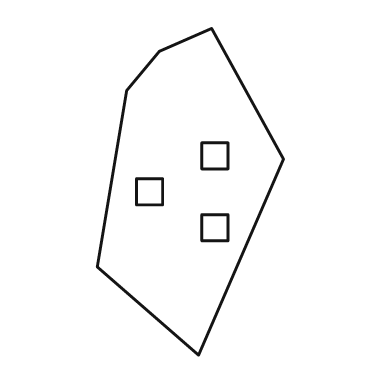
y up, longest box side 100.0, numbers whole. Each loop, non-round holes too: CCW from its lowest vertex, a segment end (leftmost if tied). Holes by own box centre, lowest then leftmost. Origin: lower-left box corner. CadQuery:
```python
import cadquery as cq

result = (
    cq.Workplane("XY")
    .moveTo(31.0, 0.0)
    .lineTo(57.0, 60.0)
    .lineTo(35.0, 100.0)
    .lineTo(19.0, 93.0)
    .lineTo(9.0, 81.0)
    .lineTo(0.0, 27.0)
    .close()
    .moveTo(32.0, 35.0)
    .lineTo(40.0, 35.0)
    .lineTo(40.0, 43.0)
    .lineTo(32.0, 43.0)
    .close()
    .moveTo(12.0, 46.0)
    .lineTo(20.0, 46.0)
    .lineTo(20.0, 54.0)
    .lineTo(12.0, 54.0)
    .close()
    .moveTo(32.0, 57.0)
    .lineTo(40.0, 57.0)
    .lineTo(40.0, 65.0)
    .lineTo(32.0, 65.0)
    .close()
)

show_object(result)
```